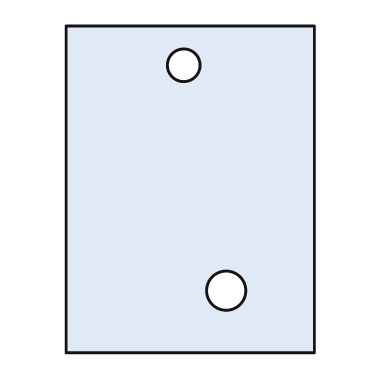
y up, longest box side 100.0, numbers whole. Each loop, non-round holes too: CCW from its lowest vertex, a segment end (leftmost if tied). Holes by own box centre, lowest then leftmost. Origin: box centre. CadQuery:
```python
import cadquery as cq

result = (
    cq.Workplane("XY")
    .moveTo(-38.0, -50.0)
    .lineTo(38.0, -50.0)
    .lineTo(38.0, 50.0)
    .lineTo(-38.0, 50.0)
    .close()
    .moveTo(11.0, -31.0)
    .circle(6.0)
    .moveTo(-2.0, 38.0)
    .circle(5.0)
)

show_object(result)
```